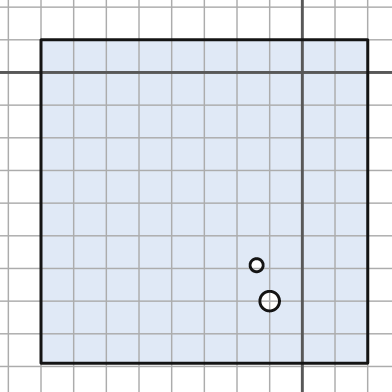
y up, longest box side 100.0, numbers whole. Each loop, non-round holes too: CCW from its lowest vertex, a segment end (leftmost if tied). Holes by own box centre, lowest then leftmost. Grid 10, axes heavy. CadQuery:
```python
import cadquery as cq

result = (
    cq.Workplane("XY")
    .moveTo(-80.0, -89.0)
    .lineTo(20.0, -89.0)
    .lineTo(20.0, 10.0)
    .lineTo(-80.0, 10.0)
    .close()
    .moveTo(-10.0, -70.0)
    .circle(3.0)
    .moveTo(-14.0, -59.0)
    .circle(2.0)
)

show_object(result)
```